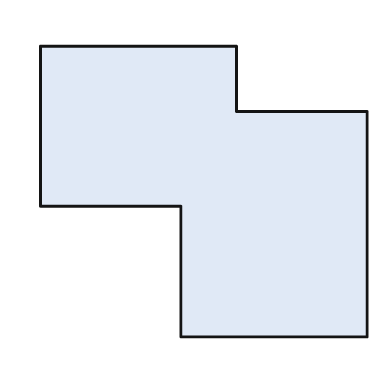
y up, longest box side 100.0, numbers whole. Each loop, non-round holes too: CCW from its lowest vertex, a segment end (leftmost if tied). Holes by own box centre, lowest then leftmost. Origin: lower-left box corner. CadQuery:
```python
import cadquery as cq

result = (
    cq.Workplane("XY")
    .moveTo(43.0, 0.0)
    .lineTo(100.0, 0.0)
    .lineTo(100.0, 69.0)
    .lineTo(60.0, 69.0)
    .lineTo(60.0, 89.0)
    .lineTo(0.0, 89.0)
    .lineTo(0.0, 40.0)
    .lineTo(43.0, 40.0)
    .close()
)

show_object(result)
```